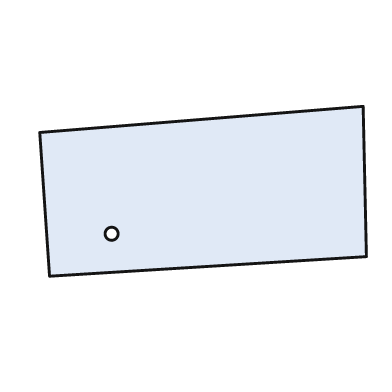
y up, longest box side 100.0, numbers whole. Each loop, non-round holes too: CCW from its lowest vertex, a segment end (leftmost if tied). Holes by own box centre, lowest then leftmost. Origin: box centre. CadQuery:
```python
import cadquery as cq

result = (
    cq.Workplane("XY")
    .moveTo(-47.0, -26.0)
    .lineTo(50.0, -20.0)
    .lineTo(49.0, 26.0)
    .lineTo(-50.0, 18.0)
    .close()
    .moveTo(-28.0, -13.0)
    .circle(2.0)
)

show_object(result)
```